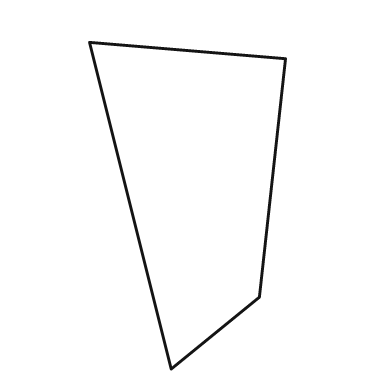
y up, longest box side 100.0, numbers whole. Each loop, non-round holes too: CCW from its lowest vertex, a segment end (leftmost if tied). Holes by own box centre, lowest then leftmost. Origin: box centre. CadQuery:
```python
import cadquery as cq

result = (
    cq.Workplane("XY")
    .moveTo(-5.0, -50.0)
    .lineTo(22.0, -28.0)
    .lineTo(30.0, 45.0)
    .lineTo(-30.0, 50.0)
    .close()
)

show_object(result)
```